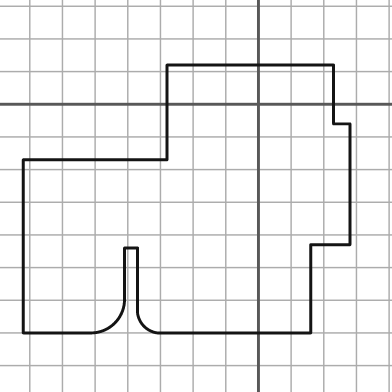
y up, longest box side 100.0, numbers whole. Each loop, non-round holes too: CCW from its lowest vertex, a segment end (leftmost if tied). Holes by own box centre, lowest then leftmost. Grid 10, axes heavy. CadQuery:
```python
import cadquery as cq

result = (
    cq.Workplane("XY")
    .moveTo(-72.0, -70.0)
    .lineTo(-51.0, -70.0)
    .threePointArc((-44.0, -67.0), (-41.0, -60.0))
    .lineTo(-41.0, -44.0)
    .lineTo(-37.0, -44.0)
    .lineTo(-37.0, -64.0)
    .threePointArc((-35.0, -68.0), (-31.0, -70.0))
    .lineTo(16.0, -70.0)
    .lineTo(16.0, -43.0)
    .lineTo(28.0, -43.0)
    .lineTo(28.0, -6.0)
    .lineTo(23.0, -6.0)
    .lineTo(23.0, 12.0)
    .lineTo(-28.0, 12.0)
    .lineTo(-28.0, -17.0)
    .lineTo(-72.0, -17.0)
    .close()
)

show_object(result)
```